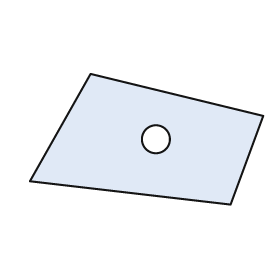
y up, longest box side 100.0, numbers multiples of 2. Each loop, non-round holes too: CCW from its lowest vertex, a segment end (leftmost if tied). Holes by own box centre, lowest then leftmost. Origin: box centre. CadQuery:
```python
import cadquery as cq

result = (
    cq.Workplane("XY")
    .moveTo(36.0, -28.0)
    .lineTo(50.0, 10.0)
    .lineTo(-24.0, 28.0)
    .lineTo(-50.0, -18.0)
    .close()
    .moveTo(4.0, 0.0)
    .circle(6.0)
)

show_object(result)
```